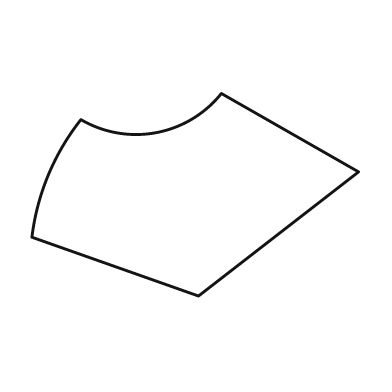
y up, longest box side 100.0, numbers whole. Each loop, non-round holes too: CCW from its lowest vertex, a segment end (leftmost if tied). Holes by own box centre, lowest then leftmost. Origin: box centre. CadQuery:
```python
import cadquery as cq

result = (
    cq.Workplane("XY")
    .moveTo(1.0, -31.0)
    .lineTo(50.0, 7.0)
    .lineTo(8.0, 31.0)
    .threePointArc((-12.0, 19.0), (-35.0, 23.0))
    .threePointArc((-45.0, 6.0), (-50.0, -13.0))
    .close()
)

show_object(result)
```